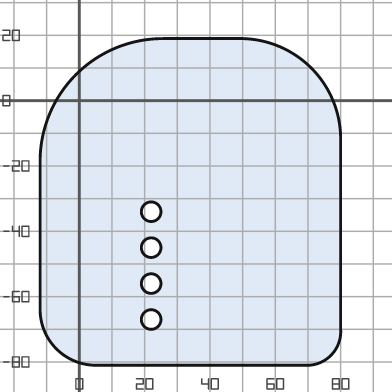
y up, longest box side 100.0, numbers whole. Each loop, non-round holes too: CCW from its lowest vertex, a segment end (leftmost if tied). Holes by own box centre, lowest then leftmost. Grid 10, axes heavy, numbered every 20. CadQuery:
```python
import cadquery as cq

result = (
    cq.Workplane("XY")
    .moveTo(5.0, -81.0)
    .lineTo(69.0, -81.0)
    .threePointArc((77.0, -78.0), (80.0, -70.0))
    .lineTo(80.0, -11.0)
    .threePointArc((71.0, 10.0), (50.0, 19.0))
    .lineTo(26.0, 19.0)
    .threePointArc((-1.0, 8.0), (-12.0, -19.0))
    .lineTo(-12.0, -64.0)
    .threePointArc((-7.0, -76.0), (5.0, -81.0))
    .close()
    .moveTo(22.0, -67.0)
    .circle(3.0)
    .moveTo(22.0, -56.0)
    .circle(3.0)
    .moveTo(22.0, -45.0)
    .circle(3.0)
    .moveTo(22.0, -34.0)
    .circle(3.0)
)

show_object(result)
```